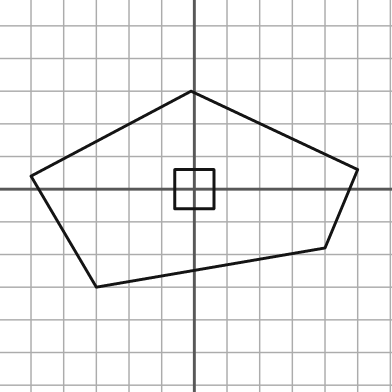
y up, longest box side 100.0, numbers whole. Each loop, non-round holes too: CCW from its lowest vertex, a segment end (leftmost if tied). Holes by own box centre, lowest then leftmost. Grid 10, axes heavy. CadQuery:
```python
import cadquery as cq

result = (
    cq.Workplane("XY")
    .moveTo(-30.0, -30.0)
    .lineTo(40.0, -18.0)
    .lineTo(50.0, 6.0)
    .lineTo(-1.0, 30.0)
    .lineTo(-50.0, 4.0)
    .close()
    .moveTo(-6.0, -6.0)
    .lineTo(6.0, -6.0)
    .lineTo(6.0, 6.0)
    .lineTo(-6.0, 6.0)
    .close()
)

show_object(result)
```